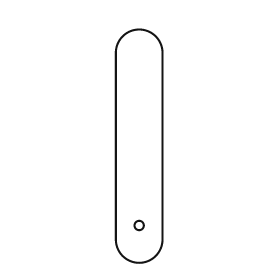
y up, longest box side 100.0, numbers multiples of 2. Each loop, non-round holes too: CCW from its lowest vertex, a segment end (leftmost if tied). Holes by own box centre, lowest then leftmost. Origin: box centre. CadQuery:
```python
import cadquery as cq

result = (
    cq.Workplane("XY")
    .moveTo(-10.0, -40.0)
    .threePointArc((0.0, -50.0), (10.0, -40.0))
    .lineTo(10.0, 40.0)
    .threePointArc((0.0, 50.0), (-10.0, 40.0))
    .close()
    .moveTo(0.0, -34.0)
    .circle(2.0)
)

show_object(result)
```